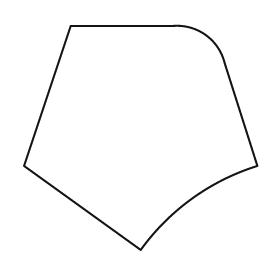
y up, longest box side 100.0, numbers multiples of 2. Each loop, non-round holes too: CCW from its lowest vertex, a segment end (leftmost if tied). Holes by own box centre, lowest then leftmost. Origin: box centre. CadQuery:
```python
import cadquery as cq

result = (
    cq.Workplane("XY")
    .moveTo(0.0, -48.0)
    .threePointArc((22.0, -26.0), (50.0, -12.0))
    .lineTo(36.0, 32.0)
    .threePointArc((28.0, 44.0), (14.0, 48.0))
    .lineTo(-30.0, 48.0)
    .lineTo(-50.0, -12.0)
    .close()
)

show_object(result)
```